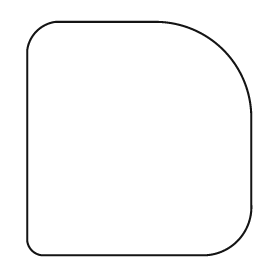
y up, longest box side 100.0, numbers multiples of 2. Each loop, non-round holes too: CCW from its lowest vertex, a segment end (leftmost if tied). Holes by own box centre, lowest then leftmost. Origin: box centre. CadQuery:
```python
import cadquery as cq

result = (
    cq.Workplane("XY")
    .moveTo(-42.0, -50.0)
    .lineTo(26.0, -50.0)
    .threePointArc((42.0, -44.0), (48.0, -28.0))
    .lineTo(48.0, 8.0)
    .threePointArc((36.0, 38.0), (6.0, 50.0))
    .lineTo(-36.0, 50.0)
    .threePointArc((-44.0, 46.0), (-48.0, 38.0))
    .lineTo(-48.0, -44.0)
    .threePointArc((-46.0, -48.0), (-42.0, -50.0))
    .close()
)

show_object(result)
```